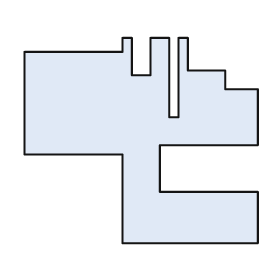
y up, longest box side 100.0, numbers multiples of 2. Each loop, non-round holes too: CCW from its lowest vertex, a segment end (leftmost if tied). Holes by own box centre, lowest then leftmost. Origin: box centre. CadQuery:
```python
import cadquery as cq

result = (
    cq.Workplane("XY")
    .moveTo(-8.0, -44.0)
    .lineTo(50.0, -44.0)
    .lineTo(50.0, -22.0)
    .lineTo(8.0, -22.0)
    .lineTo(8.0, -2.0)
    .lineTo(50.0, -2.0)
    .lineTo(50.0, 22.0)
    .lineTo(36.0, 22.0)
    .lineTo(36.0, 30.0)
    .lineTo(20.0, 30.0)
    .lineTo(20.0, 44.0)
    .lineTo(16.0, 44.0)
    .lineTo(16.0, 10.0)
    .lineTo(12.0, 10.0)
    .lineTo(12.0, 44.0)
    .lineTo(4.0, 44.0)
    .lineTo(4.0, 28.0)
    .lineTo(-4.0, 28.0)
    .lineTo(-4.0, 44.0)
    .lineTo(-8.0, 44.0)
    .lineTo(-8.0, 38.0)
    .lineTo(-50.0, 38.0)
    .lineTo(-50.0, -6.0)
    .lineTo(-8.0, -6.0)
    .close()
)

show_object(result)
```